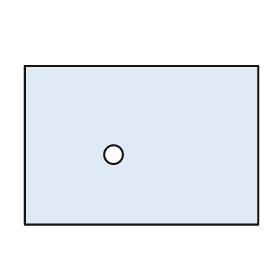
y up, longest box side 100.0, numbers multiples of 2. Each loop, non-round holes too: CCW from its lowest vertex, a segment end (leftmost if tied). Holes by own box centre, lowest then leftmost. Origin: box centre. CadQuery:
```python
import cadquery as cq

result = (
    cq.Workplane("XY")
    .moveTo(-50.0, -34.0)
    .lineTo(50.0, -34.0)
    .lineTo(50.0, 34.0)
    .lineTo(-50.0, 34.0)
    .close()
    .moveTo(-12.0, -4.0)
    .circle(4.0)
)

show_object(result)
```